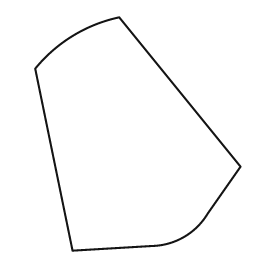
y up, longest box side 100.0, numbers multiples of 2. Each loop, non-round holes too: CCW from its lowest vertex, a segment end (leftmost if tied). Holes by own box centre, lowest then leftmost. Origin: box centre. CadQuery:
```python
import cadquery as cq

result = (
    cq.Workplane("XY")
    .moveTo(-28.0, -50.0)
    .lineTo(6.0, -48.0)
    .threePointArc((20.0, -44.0), (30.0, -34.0))
    .lineTo(44.0, -14.0)
    .lineTo(-8.0, 50.0)
    .threePointArc((-28.0, 42.0), (-44.0, 28.0))
    .close()
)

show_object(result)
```